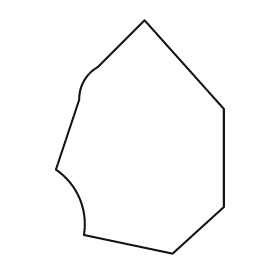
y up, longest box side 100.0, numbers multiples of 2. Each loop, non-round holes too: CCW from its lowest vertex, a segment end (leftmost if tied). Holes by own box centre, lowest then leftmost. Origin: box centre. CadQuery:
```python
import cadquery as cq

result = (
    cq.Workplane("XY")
    .moveTo(14.0, -50.0)
    .lineTo(36.0, -30.0)
    .lineTo(36.0, 12.0)
    .lineTo(2.0, 50.0)
    .lineTo(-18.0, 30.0)
    .threePointArc((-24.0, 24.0), (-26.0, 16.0))
    .lineTo(-36.0, -14.0)
    .threePointArc((-26.0, -26.0), (-24.0, -42.0))
    .close()
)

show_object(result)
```